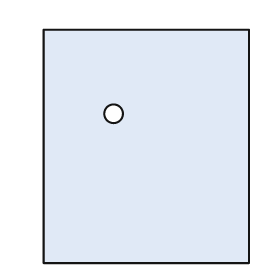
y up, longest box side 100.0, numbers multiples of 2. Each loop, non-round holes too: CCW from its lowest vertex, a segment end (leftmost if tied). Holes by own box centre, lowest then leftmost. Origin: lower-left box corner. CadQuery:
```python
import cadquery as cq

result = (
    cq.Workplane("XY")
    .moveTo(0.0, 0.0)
    .lineTo(88.0, 0.0)
    .lineTo(88.0, 100.0)
    .lineTo(0.0, 100.0)
    .close()
    .moveTo(30.0, 64.0)
    .circle(4.0)
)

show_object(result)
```